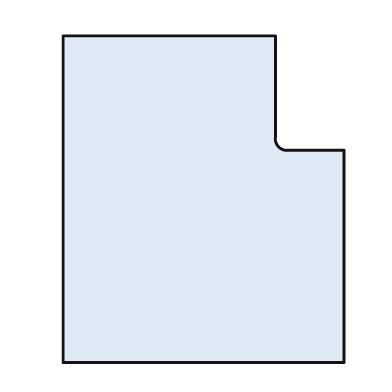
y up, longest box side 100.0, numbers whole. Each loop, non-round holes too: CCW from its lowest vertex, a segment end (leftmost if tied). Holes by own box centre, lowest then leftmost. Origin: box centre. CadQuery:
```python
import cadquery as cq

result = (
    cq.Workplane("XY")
    .moveTo(-43.0, -50.0)
    .lineTo(43.0, -50.0)
    .lineTo(43.0, 15.0)
    .lineTo(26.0, 15.0)
    .threePointArc((23.0, 16.0), (22.0, 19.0))
    .lineTo(22.0, 50.0)
    .lineTo(-43.0, 50.0)
    .close()
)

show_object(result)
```